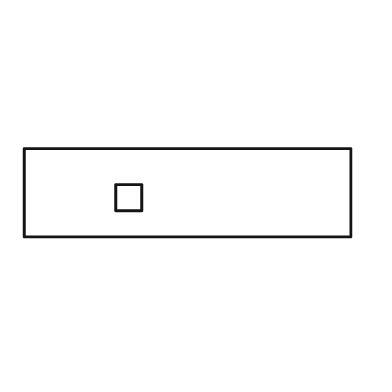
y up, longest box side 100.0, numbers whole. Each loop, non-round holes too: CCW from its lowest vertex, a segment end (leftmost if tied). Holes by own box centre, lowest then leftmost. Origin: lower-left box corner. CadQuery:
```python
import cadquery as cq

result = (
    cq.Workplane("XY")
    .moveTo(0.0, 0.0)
    .lineTo(100.0, 0.0)
    .lineTo(100.0, 27.0)
    .lineTo(0.0, 27.0)
    .close()
    .moveTo(28.0, 8.0)
    .lineTo(36.0, 8.0)
    .lineTo(36.0, 16.0)
    .lineTo(28.0, 16.0)
    .close()
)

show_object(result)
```